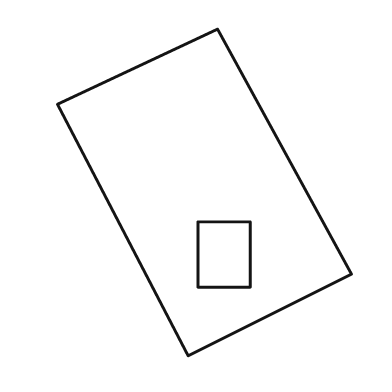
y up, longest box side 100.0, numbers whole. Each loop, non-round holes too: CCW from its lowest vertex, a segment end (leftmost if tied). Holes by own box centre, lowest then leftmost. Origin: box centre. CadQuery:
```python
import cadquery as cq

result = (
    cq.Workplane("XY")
    .moveTo(-5.0, -50.0)
    .lineTo(45.0, -25.0)
    .lineTo(4.0, 50.0)
    .lineTo(-45.0, 27.0)
    .close()
    .moveTo(-2.0, -29.0)
    .lineTo(14.0, -29.0)
    .lineTo(14.0, -9.0)
    .lineTo(-2.0, -9.0)
    .close()
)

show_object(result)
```